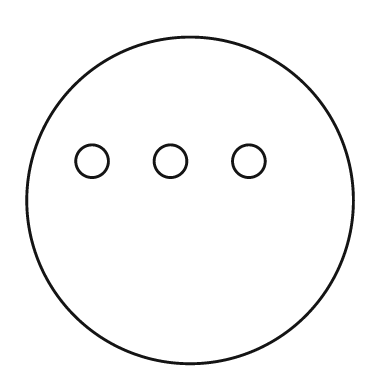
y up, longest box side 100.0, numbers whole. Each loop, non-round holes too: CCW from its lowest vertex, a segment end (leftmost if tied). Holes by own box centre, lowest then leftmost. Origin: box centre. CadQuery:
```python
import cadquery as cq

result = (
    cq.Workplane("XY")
    .moveTo(0.0, 0.0)
    .circle(50.0)
    .moveTo(-30.0, 12.0)
    .circle(5.0)
    .moveTo(-6.0, 12.0)
    .circle(5.0)
    .moveTo(18.0, 12.0)
    .circle(5.0)
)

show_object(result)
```